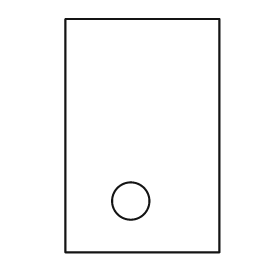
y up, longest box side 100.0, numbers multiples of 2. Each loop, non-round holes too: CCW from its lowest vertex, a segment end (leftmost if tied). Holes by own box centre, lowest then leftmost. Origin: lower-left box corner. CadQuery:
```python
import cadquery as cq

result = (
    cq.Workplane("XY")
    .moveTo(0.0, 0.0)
    .lineTo(66.0, 0.0)
    .lineTo(66.0, 100.0)
    .lineTo(0.0, 100.0)
    .close()
    .moveTo(28.0, 22.0)
    .circle(8.0)
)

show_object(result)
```